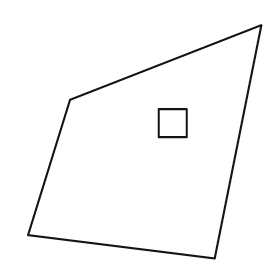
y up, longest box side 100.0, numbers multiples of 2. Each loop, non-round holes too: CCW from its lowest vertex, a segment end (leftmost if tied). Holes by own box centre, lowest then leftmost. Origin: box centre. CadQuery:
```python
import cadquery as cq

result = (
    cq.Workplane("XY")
    .moveTo(30.0, -50.0)
    .lineTo(50.0, 50.0)
    .lineTo(-32.0, 18.0)
    .lineTo(-50.0, -40.0)
    .close()
    .moveTo(6.0, 2.0)
    .lineTo(18.0, 2.0)
    .lineTo(18.0, 14.0)
    .lineTo(6.0, 14.0)
    .close()
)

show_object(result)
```